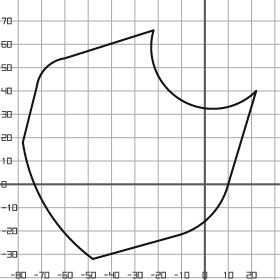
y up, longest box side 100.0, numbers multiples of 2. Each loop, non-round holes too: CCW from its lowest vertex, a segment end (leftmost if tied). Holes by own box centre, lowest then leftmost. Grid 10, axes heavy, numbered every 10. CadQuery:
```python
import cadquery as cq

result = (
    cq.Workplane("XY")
    .moveTo(-48.0, -32.0)
    .lineTo(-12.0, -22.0)
    .threePointArc((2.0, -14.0), (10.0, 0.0))
    .lineTo(22.0, 40.0)
    .threePointArc((-10.0, 36.0), (-22.0, 66.0))
    .lineTo(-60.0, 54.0)
    .threePointArc((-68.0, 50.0), (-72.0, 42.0))
    .lineTo(-78.0, 18.0)
    .threePointArc((-68.0, -10.0), (-48.0, -32.0))
    .close()
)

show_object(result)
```